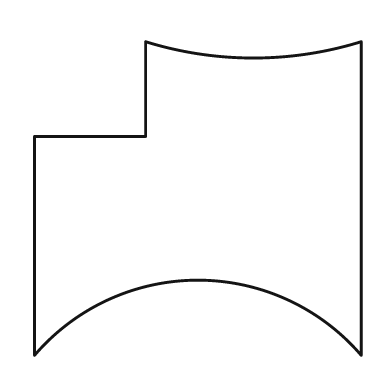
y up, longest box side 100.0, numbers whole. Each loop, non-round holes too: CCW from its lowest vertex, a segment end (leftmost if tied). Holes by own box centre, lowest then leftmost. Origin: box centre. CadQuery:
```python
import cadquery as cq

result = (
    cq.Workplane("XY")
    .moveTo(-50.0, -48.0)
    .threePointArc((0.0, -25.0), (50.0, -48.0))
    .lineTo(50.0, 48.0)
    .threePointArc((17.0, 43.0), (-16.0, 48.0))
    .lineTo(-16.0, 19.0)
    .lineTo(-50.0, 19.0)
    .close()
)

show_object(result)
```